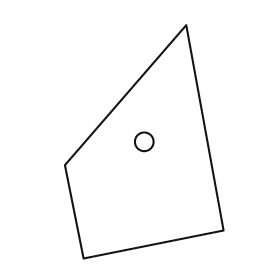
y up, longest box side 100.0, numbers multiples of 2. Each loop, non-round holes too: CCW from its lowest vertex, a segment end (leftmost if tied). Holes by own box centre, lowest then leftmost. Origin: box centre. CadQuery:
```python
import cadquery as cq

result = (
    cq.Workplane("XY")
    .moveTo(-26.0, -50.0)
    .lineTo(34.0, -38.0)
    .lineTo(18.0, 50.0)
    .lineTo(-34.0, -10.0)
    .close()
    .moveTo(0.0, 0.0)
    .circle(4.0)
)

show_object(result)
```